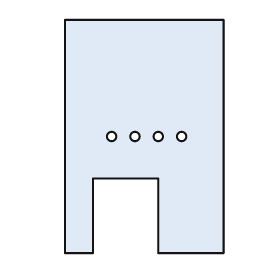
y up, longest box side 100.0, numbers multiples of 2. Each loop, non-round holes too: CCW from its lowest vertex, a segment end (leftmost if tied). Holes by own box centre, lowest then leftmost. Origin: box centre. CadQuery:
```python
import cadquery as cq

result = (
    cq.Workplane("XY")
    .moveTo(-34.0, -50.0)
    .lineTo(-22.0, -50.0)
    .lineTo(-22.0, -18.0)
    .lineTo(6.0, -18.0)
    .lineTo(6.0, -50.0)
    .lineTo(34.0, -50.0)
    .lineTo(34.0, 50.0)
    .lineTo(-34.0, 50.0)
    .close()
    .moveTo(-14.0, 0.0)
    .circle(2.0)
    .moveTo(-4.0, 0.0)
    .circle(2.0)
    .moveTo(6.0, 0.0)
    .circle(2.0)
    .moveTo(16.0, 0.0)
    .circle(2.0)
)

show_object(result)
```